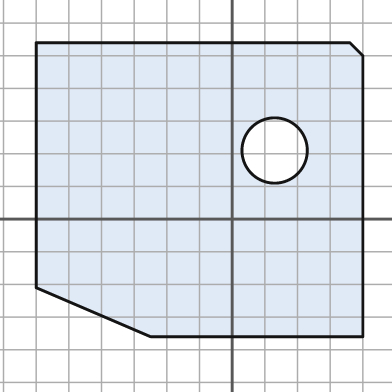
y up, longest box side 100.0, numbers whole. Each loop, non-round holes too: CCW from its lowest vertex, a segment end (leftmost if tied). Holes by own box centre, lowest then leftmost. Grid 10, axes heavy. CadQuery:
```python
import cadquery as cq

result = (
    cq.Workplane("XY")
    .moveTo(-25.0, -36.0)
    .lineTo(40.0, -36.0)
    .lineTo(40.0, 50.0)
    .lineTo(36.0, 54.0)
    .lineTo(-60.0, 54.0)
    .lineTo(-60.0, -21.0)
    .close()
    .moveTo(13.0, 21.0)
    .circle(10.0)
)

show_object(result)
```